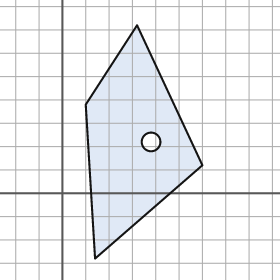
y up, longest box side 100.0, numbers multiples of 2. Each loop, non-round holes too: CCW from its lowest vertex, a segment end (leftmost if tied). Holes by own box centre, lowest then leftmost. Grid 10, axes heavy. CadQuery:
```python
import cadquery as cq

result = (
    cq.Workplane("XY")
    .moveTo(14.0, -28.0)
    .lineTo(60.0, 12.0)
    .lineTo(32.0, 72.0)
    .lineTo(10.0, 38.0)
    .close()
    .moveTo(38.0, 22.0)
    .circle(4.0)
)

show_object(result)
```